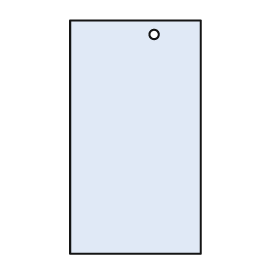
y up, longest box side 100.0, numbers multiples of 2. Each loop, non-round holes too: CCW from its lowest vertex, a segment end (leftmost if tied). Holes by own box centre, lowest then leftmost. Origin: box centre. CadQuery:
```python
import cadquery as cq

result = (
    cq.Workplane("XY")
    .moveTo(-28.0, -50.0)
    .lineTo(28.0, -50.0)
    .lineTo(28.0, 50.0)
    .lineTo(-28.0, 50.0)
    .close()
    .moveTo(8.0, 44.0)
    .circle(2.0)
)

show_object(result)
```